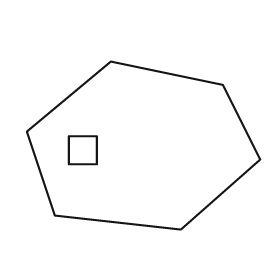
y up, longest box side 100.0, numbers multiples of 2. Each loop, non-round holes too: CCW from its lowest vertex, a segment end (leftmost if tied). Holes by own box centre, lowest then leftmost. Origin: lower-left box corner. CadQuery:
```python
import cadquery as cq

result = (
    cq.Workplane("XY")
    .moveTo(66.0, 0.0)
    .lineTo(100.0, 30.0)
    .lineTo(84.0, 62.0)
    .lineTo(36.0, 72.0)
    .lineTo(0.0, 42.0)
    .lineTo(12.0, 6.0)
    .close()
    .moveTo(18.0, 28.0)
    .lineTo(30.0, 28.0)
    .lineTo(30.0, 40.0)
    .lineTo(18.0, 40.0)
    .close()
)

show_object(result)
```